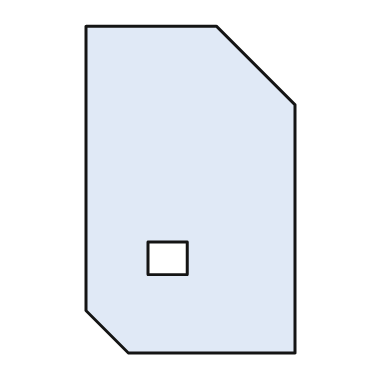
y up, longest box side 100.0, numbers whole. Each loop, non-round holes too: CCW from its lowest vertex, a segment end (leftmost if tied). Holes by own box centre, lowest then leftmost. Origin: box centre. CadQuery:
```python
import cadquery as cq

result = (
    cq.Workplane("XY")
    .moveTo(-19.0, -50.0)
    .lineTo(32.0, -50.0)
    .lineTo(32.0, 26.0)
    .lineTo(8.0, 50.0)
    .lineTo(-32.0, 50.0)
    .lineTo(-32.0, -37.0)
    .close()
    .moveTo(-13.0, -26.0)
    .lineTo(-1.0, -26.0)
    .lineTo(-1.0, -16.0)
    .lineTo(-13.0, -16.0)
    .close()
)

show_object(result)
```